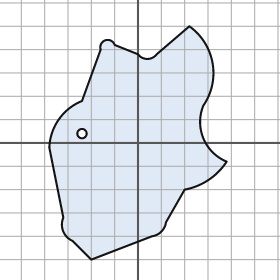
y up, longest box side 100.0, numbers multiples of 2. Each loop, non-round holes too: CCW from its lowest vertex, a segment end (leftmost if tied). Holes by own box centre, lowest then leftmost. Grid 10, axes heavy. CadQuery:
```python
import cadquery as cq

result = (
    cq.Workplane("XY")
    .moveTo(-20.0, -50.0)
    .lineTo(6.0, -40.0)
    .threePointArc((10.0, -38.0), (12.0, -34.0))
    .lineTo(20.0, -20.0)
    .threePointArc((30.0, -16.0), (38.0, -8.0))
    .threePointArc((28.0, 2.0), (28.0, 16.0))
    .threePointArc((32.0, 34.0), (22.0, 50.0))
    .lineTo(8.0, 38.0)
    .threePointArc((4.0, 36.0), (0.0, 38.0))
    .lineTo(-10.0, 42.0)
    .threePointArc((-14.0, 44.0), (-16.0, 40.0))
    .lineTo(-24.0, 18.0)
    .threePointArc((-34.0, 10.0), (-38.0, -2.0))
    .lineTo(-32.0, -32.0)
    .threePointArc((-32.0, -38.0), (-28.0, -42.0))
    .close()
    .moveTo(-24.0, 4.0)
    .circle(2.0)
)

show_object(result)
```